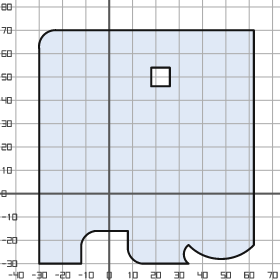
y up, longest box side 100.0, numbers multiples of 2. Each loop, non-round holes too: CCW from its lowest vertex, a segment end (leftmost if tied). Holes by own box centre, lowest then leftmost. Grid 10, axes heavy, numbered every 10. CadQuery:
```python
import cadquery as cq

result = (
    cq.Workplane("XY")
    .moveTo(-30.0, -30.0)
    .lineTo(-12.0, -30.0)
    .lineTo(-12.0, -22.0)
    .threePointArc((-10.0, -18.0), (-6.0, -16.0))
    .lineTo(8.0, -16.0)
    .lineTo(8.0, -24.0)
    .threePointArc((10.0, -28.0), (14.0, -30.0))
    .lineTo(34.0, -30.0)
    .threePointArc((32.0, -26.0), (34.0, -22.0))
    .threePointArc((48.0, -28.0), (62.0, -22.0))
    .lineTo(62.0, 70.0)
    .lineTo(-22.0, 70.0)
    .threePointArc((-28.0, 68.0), (-30.0, 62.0))
    .close()
    .moveTo(18.0, 46.0)
    .lineTo(26.0, 46.0)
    .lineTo(26.0, 54.0)
    .lineTo(18.0, 54.0)
    .close()
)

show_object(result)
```